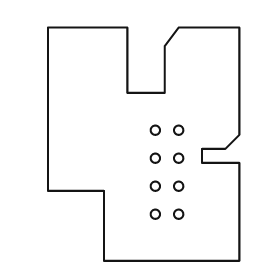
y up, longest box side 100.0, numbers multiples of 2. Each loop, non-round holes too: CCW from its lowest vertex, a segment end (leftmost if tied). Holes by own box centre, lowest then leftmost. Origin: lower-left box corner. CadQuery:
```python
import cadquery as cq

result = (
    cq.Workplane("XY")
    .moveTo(24.0, 0.0)
    .lineTo(82.0, 0.0)
    .lineTo(82.0, 42.0)
    .lineTo(66.0, 42.0)
    .lineTo(66.0, 48.0)
    .lineTo(76.0, 48.0)
    .lineTo(82.0, 54.0)
    .lineTo(82.0, 100.0)
    .lineTo(56.0, 100.0)
    .lineTo(50.0, 92.0)
    .lineTo(50.0, 72.0)
    .lineTo(34.0, 72.0)
    .lineTo(34.0, 100.0)
    .lineTo(0.0, 100.0)
    .lineTo(0.0, 30.0)
    .lineTo(24.0, 30.0)
    .close()
    .moveTo(46.0, 20.0)
    .circle(2.0)
    .moveTo(56.0, 20.0)
    .circle(2.0)
    .moveTo(46.0, 32.0)
    .circle(2.0)
    .moveTo(56.0, 32.0)
    .circle(2.0)
    .moveTo(46.0, 44.0)
    .circle(2.0)
    .moveTo(56.0, 44.0)
    .circle(2.0)
    .moveTo(46.0, 56.0)
    .circle(2.0)
    .moveTo(56.0, 56.0)
    .circle(2.0)
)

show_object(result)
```